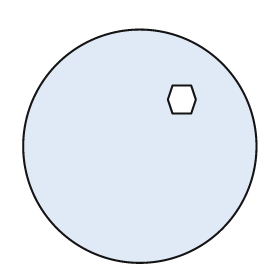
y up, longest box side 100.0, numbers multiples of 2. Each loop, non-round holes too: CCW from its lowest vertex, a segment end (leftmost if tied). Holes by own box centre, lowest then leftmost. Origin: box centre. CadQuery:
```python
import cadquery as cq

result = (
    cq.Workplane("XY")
    .moveTo(0.0, 0.0)
    .circle(50.0)
    .moveTo(14.0, 14.0)
    .lineTo(22.0, 14.0)
    .lineTo(24.0, 20.0)
    .lineTo(22.0, 26.0)
    .lineTo(14.0, 26.0)
    .lineTo(12.0, 20.0)
    .close()
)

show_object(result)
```